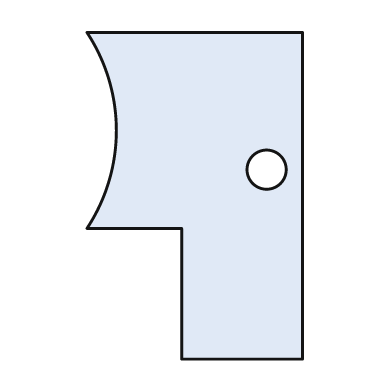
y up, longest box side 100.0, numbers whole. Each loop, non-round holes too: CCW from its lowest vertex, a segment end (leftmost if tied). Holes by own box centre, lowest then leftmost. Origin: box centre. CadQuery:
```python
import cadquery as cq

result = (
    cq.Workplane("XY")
    .moveTo(-4.0, -50.0)
    .lineTo(33.0, -50.0)
    .lineTo(33.0, 50.0)
    .lineTo(-33.0, 50.0)
    .threePointArc((-24.0, 20.0), (-33.0, -10.0))
    .lineTo(-4.0, -10.0)
    .close()
    .moveTo(22.0, 8.0)
    .circle(6.0)
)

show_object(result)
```